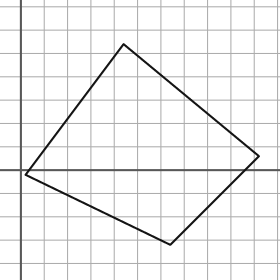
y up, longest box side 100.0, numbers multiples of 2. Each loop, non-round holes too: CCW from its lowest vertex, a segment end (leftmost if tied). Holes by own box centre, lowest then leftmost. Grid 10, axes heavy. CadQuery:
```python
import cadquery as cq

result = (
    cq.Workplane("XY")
    .moveTo(64.0, -32.0)
    .lineTo(102.0, 6.0)
    .lineTo(44.0, 54.0)
    .lineTo(2.0, -2.0)
    .close()
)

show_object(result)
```